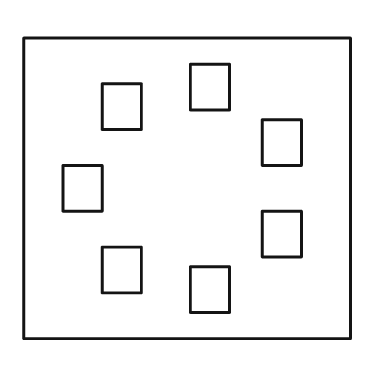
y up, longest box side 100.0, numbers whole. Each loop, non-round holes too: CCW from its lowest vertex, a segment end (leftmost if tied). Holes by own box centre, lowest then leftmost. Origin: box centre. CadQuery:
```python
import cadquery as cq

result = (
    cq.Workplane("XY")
    .moveTo(-50.0, -46.0)
    .lineTo(50.0, -46.0)
    .lineTo(50.0, 46.0)
    .lineTo(-50.0, 46.0)
    .close()
    .moveTo(1.0, -38.0)
    .lineTo(13.0, -38.0)
    .lineTo(13.0, -24.0)
    .lineTo(1.0, -24.0)
    .close()
    .moveTo(-26.0, -32.0)
    .lineTo(-14.0, -32.0)
    .lineTo(-14.0, -18.0)
    .lineTo(-26.0, -18.0)
    .close()
    .moveTo(23.0, -21.0)
    .lineTo(35.0, -21.0)
    .lineTo(35.0, -7.0)
    .lineTo(23.0, -7.0)
    .close()
    .moveTo(-38.0, -7.0)
    .lineTo(-26.0, -7.0)
    .lineTo(-26.0, 7.0)
    .lineTo(-38.0, 7.0)
    .close()
    .moveTo(23.0, 7.0)
    .lineTo(35.0, 7.0)
    .lineTo(35.0, 21.0)
    .lineTo(23.0, 21.0)
    .close()
    .moveTo(-26.0, 18.0)
    .lineTo(-14.0, 18.0)
    .lineTo(-14.0, 32.0)
    .lineTo(-26.0, 32.0)
    .close()
    .moveTo(1.0, 24.0)
    .lineTo(13.0, 24.0)
    .lineTo(13.0, 38.0)
    .lineTo(1.0, 38.0)
    .close()
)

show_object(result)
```